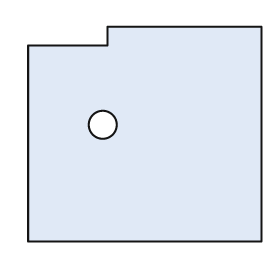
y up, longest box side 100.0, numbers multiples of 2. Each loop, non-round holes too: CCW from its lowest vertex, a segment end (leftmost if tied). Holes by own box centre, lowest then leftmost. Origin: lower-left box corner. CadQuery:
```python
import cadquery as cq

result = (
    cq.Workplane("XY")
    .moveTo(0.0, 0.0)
    .lineTo(100.0, 0.0)
    .lineTo(100.0, 92.0)
    .lineTo(34.0, 92.0)
    .lineTo(34.0, 84.0)
    .lineTo(0.0, 84.0)
    .close()
    .moveTo(32.0, 50.0)
    .circle(6.0)
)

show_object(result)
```